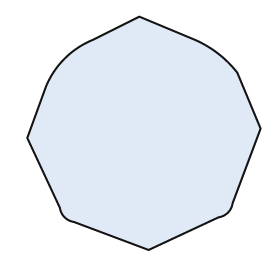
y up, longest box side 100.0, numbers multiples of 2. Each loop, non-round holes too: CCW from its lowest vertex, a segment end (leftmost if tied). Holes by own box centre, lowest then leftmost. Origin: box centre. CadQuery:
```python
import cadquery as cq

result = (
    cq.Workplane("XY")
    .moveTo(2.0, -50.0)
    .lineTo(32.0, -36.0)
    .threePointArc((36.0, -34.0), (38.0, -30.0))
    .lineTo(50.0, 2.0)
    .lineTo(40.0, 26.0)
    .threePointArc((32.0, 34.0), (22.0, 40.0))
    .lineTo(-2.0, 50.0)
    .lineTo(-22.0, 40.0)
    .threePointArc((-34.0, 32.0), (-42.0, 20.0))
    .lineTo(-50.0, -2.0)
    .lineTo(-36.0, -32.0)
    .threePointArc((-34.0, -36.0), (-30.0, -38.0))
    .close()
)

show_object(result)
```